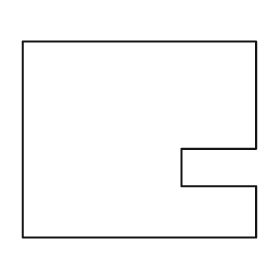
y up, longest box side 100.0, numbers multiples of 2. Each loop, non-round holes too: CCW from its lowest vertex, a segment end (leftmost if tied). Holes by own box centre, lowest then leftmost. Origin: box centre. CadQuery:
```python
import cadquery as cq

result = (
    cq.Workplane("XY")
    .moveTo(-50.0, -42.0)
    .lineTo(50.0, -42.0)
    .lineTo(50.0, -20.0)
    .lineTo(18.0, -20.0)
    .lineTo(18.0, -4.0)
    .lineTo(50.0, -4.0)
    .lineTo(50.0, 42.0)
    .lineTo(-50.0, 42.0)
    .close()
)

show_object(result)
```